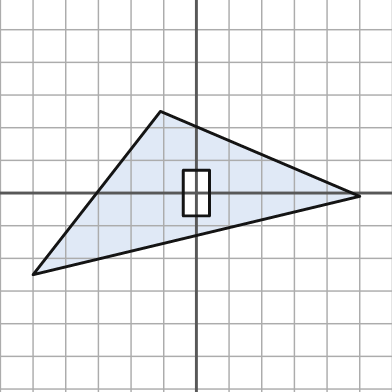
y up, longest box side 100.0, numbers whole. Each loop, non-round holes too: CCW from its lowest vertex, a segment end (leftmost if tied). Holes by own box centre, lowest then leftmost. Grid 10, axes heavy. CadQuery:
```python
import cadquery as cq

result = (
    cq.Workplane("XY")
    .moveTo(-50.0, -25.0)
    .lineTo(50.0, -1.0)
    .lineTo(-11.0, 25.0)
    .close()
    .moveTo(-4.0, -7.0)
    .lineTo(4.0, -7.0)
    .lineTo(4.0, 7.0)
    .lineTo(-4.0, 7.0)
    .close()
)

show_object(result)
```